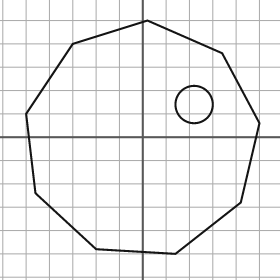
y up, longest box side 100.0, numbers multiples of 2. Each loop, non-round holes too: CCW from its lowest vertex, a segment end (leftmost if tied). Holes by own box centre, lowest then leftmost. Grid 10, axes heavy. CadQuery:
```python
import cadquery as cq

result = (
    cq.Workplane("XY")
    .moveTo(14.0, -50.0)
    .lineTo(42.0, -28.0)
    .lineTo(50.0, 6.0)
    .lineTo(34.0, 36.0)
    .lineTo(2.0, 50.0)
    .lineTo(-30.0, 40.0)
    .lineTo(-50.0, 10.0)
    .lineTo(-46.0, -24.0)
    .lineTo(-20.0, -48.0)
    .close()
    .moveTo(22.0, 14.0)
    .circle(8.0)
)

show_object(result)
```